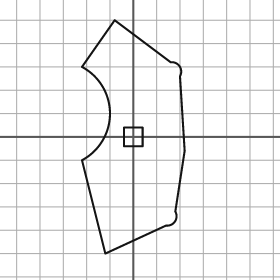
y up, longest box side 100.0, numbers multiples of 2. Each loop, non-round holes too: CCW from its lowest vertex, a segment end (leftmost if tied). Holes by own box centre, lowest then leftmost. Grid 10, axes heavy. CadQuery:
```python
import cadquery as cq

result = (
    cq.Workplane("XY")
    .moveTo(-12.0, -50.0)
    .lineTo(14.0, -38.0)
    .threePointArc((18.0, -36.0), (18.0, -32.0))
    .lineTo(22.0, -6.0)
    .lineTo(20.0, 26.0)
    .threePointArc((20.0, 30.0), (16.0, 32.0))
    .lineTo(-8.0, 50.0)
    .lineTo(-22.0, 30.0)
    .threePointArc((-10.0, 10.0), (-22.0, -10.0))
    .close()
    .moveTo(-4.0, -4.0)
    .lineTo(4.0, -4.0)
    .lineTo(4.0, 4.0)
    .lineTo(-4.0, 4.0)
    .close()
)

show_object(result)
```